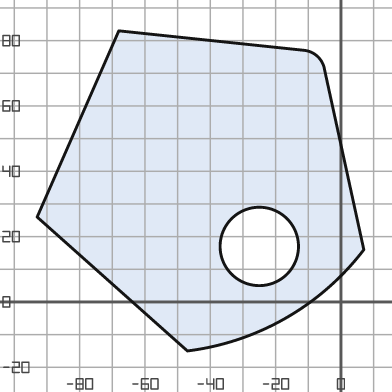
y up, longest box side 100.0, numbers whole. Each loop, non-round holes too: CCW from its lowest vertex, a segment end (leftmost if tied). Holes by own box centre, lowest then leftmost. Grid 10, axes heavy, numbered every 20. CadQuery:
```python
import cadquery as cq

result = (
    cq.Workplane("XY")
    .moveTo(-47.0, -15.0)
    .threePointArc((-17.0, -5.0), (7.0, 16.0))
    .lineTo(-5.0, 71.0)
    .threePointArc((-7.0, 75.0), (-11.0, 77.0))
    .lineTo(-68.0, 83.0)
    .lineTo(-93.0, 26.0)
    .close()
    .moveTo(-25.0, 17.0)
    .circle(12.0)
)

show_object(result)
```